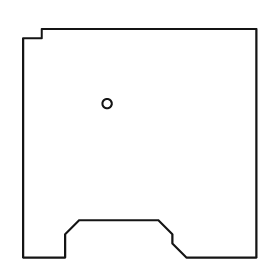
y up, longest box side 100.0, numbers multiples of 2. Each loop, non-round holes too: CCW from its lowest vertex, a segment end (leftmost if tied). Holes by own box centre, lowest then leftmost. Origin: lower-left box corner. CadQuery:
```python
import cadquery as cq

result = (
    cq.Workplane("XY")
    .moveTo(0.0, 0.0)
    .lineTo(18.0, 0.0)
    .lineTo(18.0, 10.0)
    .lineTo(24.0, 16.0)
    .lineTo(58.0, 16.0)
    .lineTo(64.0, 10.0)
    .lineTo(64.0, 6.0)
    .lineTo(70.0, 0.0)
    .lineTo(100.0, 0.0)
    .lineTo(100.0, 98.0)
    .lineTo(8.0, 98.0)
    .lineTo(8.0, 94.0)
    .lineTo(0.0, 94.0)
    .close()
    .moveTo(36.0, 66.0)
    .circle(2.0)
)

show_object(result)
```